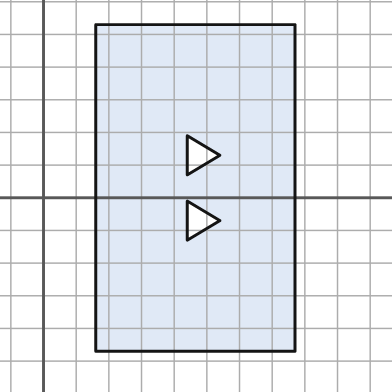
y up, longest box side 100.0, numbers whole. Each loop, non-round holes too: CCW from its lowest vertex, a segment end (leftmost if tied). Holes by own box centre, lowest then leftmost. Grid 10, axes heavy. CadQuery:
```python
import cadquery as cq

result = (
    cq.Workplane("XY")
    .moveTo(16.0, -47.0)
    .lineTo(77.0, -47.0)
    .lineTo(77.0, 53.0)
    .lineTo(16.0, 53.0)
    .close()
    .moveTo(44.0, -13.0)
    .lineTo(54.0, -7.0)
    .lineTo(44.0, -1.0)
    .close()
    .moveTo(44.0, 7.0)
    .lineTo(54.0, 13.0)
    .lineTo(44.0, 19.0)
    .close()
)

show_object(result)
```